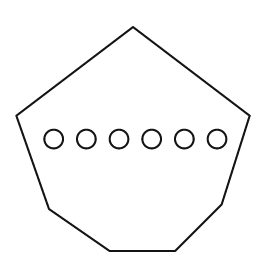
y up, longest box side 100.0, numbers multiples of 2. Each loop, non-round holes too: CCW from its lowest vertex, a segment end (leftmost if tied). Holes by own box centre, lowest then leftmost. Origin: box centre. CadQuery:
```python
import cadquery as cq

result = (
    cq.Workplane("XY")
    .moveTo(-10.0, -48.0)
    .lineTo(18.0, -48.0)
    .lineTo(38.0, -28.0)
    .lineTo(50.0, 10.0)
    .lineTo(0.0, 48.0)
    .lineTo(-50.0, 10.0)
    .lineTo(-36.0, -30.0)
    .close()
    .moveTo(-34.0, 0.0)
    .circle(4.0)
    .moveTo(-20.0, 0.0)
    .circle(4.0)
    .moveTo(-6.0, 0.0)
    .circle(4.0)
    .moveTo(8.0, 0.0)
    .circle(4.0)
    .moveTo(22.0, 0.0)
    .circle(4.0)
    .moveTo(36.0, 0.0)
    .circle(4.0)
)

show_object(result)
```